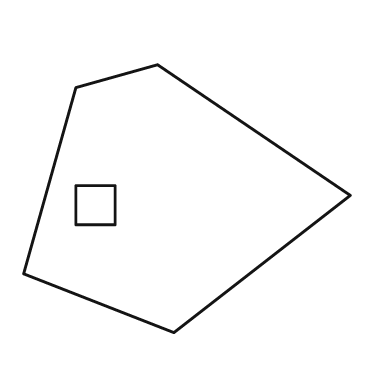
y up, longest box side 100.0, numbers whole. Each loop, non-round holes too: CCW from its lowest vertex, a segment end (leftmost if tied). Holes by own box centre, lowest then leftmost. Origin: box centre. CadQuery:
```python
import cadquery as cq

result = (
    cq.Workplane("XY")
    .moveTo(-4.0, -41.0)
    .lineTo(50.0, 1.0)
    .lineTo(-9.0, 41.0)
    .lineTo(-34.0, 34.0)
    .lineTo(-50.0, -23.0)
    .close()
    .moveTo(-34.0, -8.0)
    .lineTo(-22.0, -8.0)
    .lineTo(-22.0, 4.0)
    .lineTo(-34.0, 4.0)
    .close()
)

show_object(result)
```